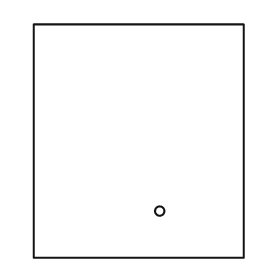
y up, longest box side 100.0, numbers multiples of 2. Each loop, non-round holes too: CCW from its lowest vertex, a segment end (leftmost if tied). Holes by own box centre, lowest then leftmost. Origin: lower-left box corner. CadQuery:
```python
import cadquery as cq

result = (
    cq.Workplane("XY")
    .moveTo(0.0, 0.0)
    .lineTo(90.0, 0.0)
    .lineTo(90.0, 100.0)
    .lineTo(0.0, 100.0)
    .close()
    .moveTo(54.0, 20.0)
    .circle(2.0)
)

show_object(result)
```